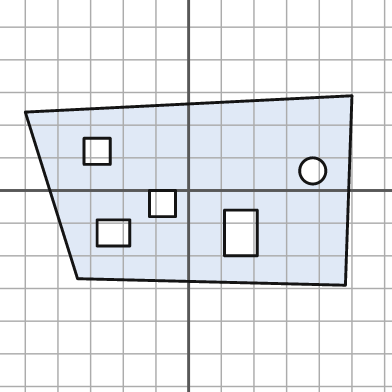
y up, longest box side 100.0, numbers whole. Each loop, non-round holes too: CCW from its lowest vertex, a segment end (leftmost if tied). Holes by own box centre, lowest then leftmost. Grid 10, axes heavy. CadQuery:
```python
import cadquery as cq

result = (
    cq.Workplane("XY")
    .moveTo(48.0, -29.0)
    .lineTo(50.0, 29.0)
    .lineTo(-50.0, 24.0)
    .lineTo(-34.0, -27.0)
    .close()
    .moveTo(-28.0, -17.0)
    .lineTo(-18.0, -17.0)
    .lineTo(-18.0, -9.0)
    .lineTo(-28.0, -9.0)
    .close()
    .moveTo(11.0, -20.0)
    .lineTo(21.0, -20.0)
    .lineTo(21.0, -6.0)
    .lineTo(11.0, -6.0)
    .close()
    .moveTo(-12.0, -8.0)
    .lineTo(-4.0, -8.0)
    .lineTo(-4.0, 0.0)
    .lineTo(-12.0, 0.0)
    .close()
    .moveTo(38.0, 6.0)
    .circle(4.0)
    .moveTo(-32.0, 8.0)
    .lineTo(-24.0, 8.0)
    .lineTo(-24.0, 16.0)
    .lineTo(-32.0, 16.0)
    .close()
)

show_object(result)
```